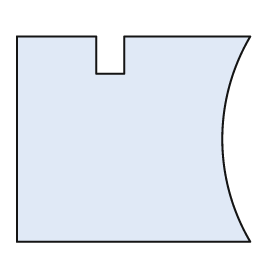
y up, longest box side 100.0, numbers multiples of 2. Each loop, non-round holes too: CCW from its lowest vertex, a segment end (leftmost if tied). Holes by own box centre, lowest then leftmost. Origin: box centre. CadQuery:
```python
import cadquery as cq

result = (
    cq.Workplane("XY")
    .moveTo(-50.0, -44.0)
    .lineTo(50.0, -44.0)
    .threePointArc((38.0, 0.0), (50.0, 44.0))
    .lineTo(-4.0, 44.0)
    .lineTo(-4.0, 28.0)
    .lineTo(-16.0, 28.0)
    .lineTo(-16.0, 44.0)
    .lineTo(-50.0, 44.0)
    .close()
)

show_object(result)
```